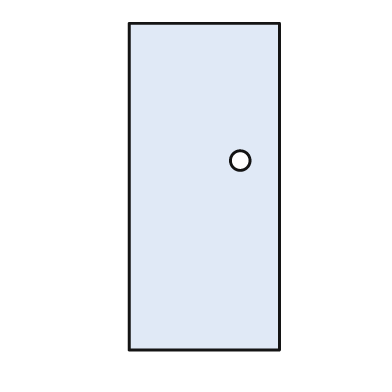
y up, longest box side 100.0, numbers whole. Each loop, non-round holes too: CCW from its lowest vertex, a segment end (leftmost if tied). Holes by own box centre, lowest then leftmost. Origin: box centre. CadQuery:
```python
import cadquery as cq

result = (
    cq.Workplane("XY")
    .moveTo(-23.0, -50.0)
    .lineTo(23.0, -50.0)
    .lineTo(23.0, 50.0)
    .lineTo(-23.0, 50.0)
    .close()
    .moveTo(11.0, 8.0)
    .circle(3.0)
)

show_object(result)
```